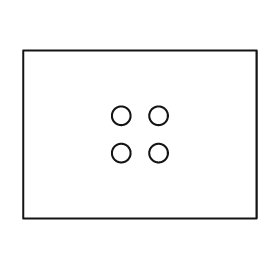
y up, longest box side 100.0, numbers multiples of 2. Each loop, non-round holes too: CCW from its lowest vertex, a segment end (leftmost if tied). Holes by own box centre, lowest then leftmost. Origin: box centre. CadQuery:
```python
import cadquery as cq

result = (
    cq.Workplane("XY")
    .moveTo(-50.0, -36.0)
    .lineTo(50.0, -36.0)
    .lineTo(50.0, 36.0)
    .lineTo(-50.0, 36.0)
    .close()
    .moveTo(-8.0, -8.0)
    .circle(4.0)
    .moveTo(8.0, -8.0)
    .circle(4.0)
    .moveTo(-8.0, 8.0)
    .circle(4.0)
    .moveTo(8.0, 8.0)
    .circle(4.0)
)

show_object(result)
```